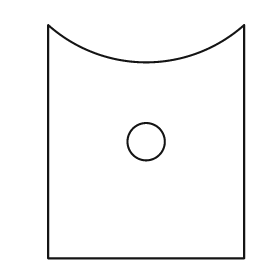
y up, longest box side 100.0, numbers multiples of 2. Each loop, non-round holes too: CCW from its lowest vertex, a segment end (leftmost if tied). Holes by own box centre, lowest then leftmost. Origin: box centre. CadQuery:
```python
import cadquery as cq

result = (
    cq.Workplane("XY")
    .moveTo(-42.0, -50.0)
    .lineTo(42.0, -50.0)
    .lineTo(42.0, 50.0)
    .threePointArc((0.0, 34.0), (-42.0, 50.0))
    .close()
    .moveTo(0.0, 0.0)
    .circle(8.0)
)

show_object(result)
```